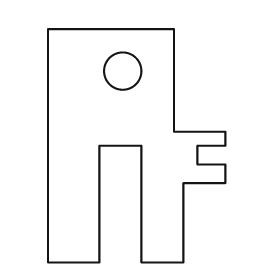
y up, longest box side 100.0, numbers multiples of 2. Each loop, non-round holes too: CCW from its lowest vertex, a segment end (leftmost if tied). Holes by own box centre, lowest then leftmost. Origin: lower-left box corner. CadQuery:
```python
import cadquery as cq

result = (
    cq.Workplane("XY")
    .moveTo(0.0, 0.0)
    .lineTo(22.0, 0.0)
    .lineTo(22.0, 50.0)
    .lineTo(40.0, 50.0)
    .lineTo(40.0, 0.0)
    .lineTo(58.0, 0.0)
    .lineTo(58.0, 34.0)
    .lineTo(76.0, 34.0)
    .lineTo(76.0, 42.0)
    .lineTo(64.0, 42.0)
    .lineTo(64.0, 50.0)
    .lineTo(76.0, 50.0)
    .lineTo(76.0, 56.0)
    .lineTo(54.0, 56.0)
    .lineTo(54.0, 100.0)
    .lineTo(0.0, 100.0)
    .close()
    .moveTo(32.0, 82.0)
    .circle(8.0)
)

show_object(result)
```